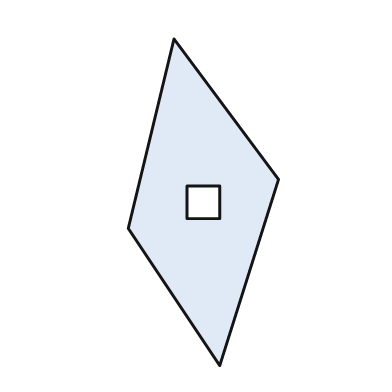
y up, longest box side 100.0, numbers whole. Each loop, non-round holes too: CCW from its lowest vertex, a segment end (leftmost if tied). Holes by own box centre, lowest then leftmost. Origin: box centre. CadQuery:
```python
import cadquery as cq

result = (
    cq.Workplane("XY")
    .moveTo(5.0, -50.0)
    .lineTo(23.0, 7.0)
    .lineTo(-9.0, 50.0)
    .lineTo(-23.0, -8.0)
    .close()
    .moveTo(-5.0, -5.0)
    .lineTo(5.0, -5.0)
    .lineTo(5.0, 5.0)
    .lineTo(-5.0, 5.0)
    .close()
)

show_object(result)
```